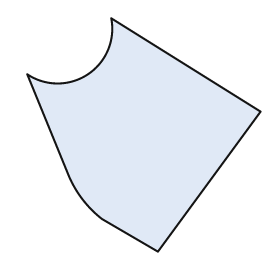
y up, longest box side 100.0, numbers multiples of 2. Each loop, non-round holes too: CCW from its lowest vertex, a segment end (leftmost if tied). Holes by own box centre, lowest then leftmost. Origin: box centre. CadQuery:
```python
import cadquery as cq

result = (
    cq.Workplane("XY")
    .moveTo(6.0, -50.0)
    .lineTo(50.0, 10.0)
    .lineTo(-14.0, 50.0)
    .threePointArc((-24.0, 26.0), (-50.0, 26.0))
    .lineTo(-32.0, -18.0)
    .threePointArc((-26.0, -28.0), (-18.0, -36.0))
    .close()
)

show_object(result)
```